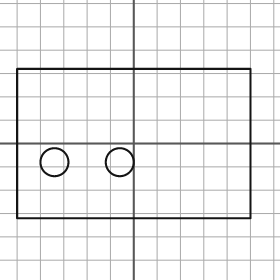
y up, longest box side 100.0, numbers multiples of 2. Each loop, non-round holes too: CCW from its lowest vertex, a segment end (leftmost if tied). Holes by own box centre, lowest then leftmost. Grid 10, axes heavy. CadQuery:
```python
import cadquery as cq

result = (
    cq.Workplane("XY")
    .moveTo(-50.0, -32.0)
    .lineTo(50.0, -32.0)
    .lineTo(50.0, 32.0)
    .lineTo(-50.0, 32.0)
    .close()
    .moveTo(-34.0, -8.0)
    .circle(6.0)
    .moveTo(-6.0, -8.0)
    .circle(6.0)
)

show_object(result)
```